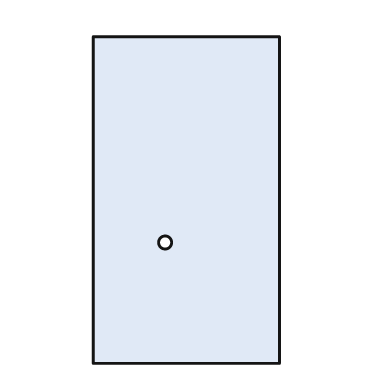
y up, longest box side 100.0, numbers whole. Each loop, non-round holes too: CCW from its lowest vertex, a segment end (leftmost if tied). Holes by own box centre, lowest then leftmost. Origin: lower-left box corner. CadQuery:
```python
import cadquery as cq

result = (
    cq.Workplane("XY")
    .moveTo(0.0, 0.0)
    .lineTo(57.0, 0.0)
    .lineTo(57.0, 100.0)
    .lineTo(0.0, 100.0)
    .close()
    .moveTo(22.0, 37.0)
    .circle(2.0)
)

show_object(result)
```